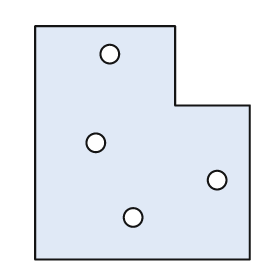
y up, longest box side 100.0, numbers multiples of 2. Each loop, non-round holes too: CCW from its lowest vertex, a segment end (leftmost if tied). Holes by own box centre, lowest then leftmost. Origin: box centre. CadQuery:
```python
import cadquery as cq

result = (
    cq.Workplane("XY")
    .moveTo(-46.0, -50.0)
    .lineTo(46.0, -50.0)
    .lineTo(46.0, 16.0)
    .lineTo(14.0, 16.0)
    .lineTo(14.0, 50.0)
    .lineTo(-46.0, 50.0)
    .close()
    .moveTo(-4.0, -32.0)
    .circle(4.0)
    .moveTo(32.0, -16.0)
    .circle(4.0)
    .moveTo(-20.0, 0.0)
    .circle(4.0)
    .moveTo(-14.0, 38.0)
    .circle(4.0)
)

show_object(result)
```